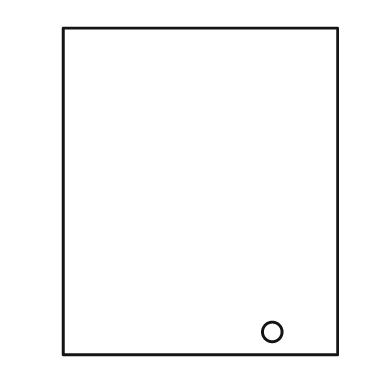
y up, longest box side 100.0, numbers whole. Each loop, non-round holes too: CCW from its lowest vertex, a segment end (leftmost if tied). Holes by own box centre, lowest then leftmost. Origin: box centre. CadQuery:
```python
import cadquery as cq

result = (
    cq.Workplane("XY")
    .moveTo(-42.0, -50.0)
    .lineTo(42.0, -50.0)
    .lineTo(42.0, 50.0)
    .lineTo(-42.0, 50.0)
    .close()
    .moveTo(22.0, -43.0)
    .circle(3.0)
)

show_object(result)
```